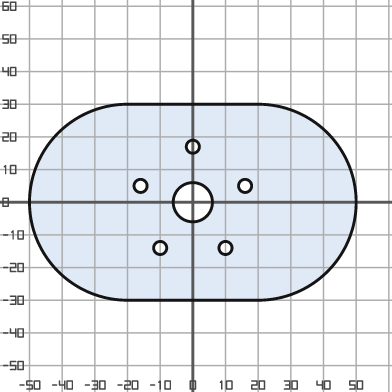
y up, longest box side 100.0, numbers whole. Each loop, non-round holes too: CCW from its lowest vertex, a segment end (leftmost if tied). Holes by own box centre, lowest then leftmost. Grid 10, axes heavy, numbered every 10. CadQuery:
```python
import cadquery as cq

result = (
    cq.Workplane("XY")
    .moveTo(-20.0, -30.0)
    .lineTo(20.0, -30.0)
    .threePointArc((50.0, 0.0), (20.0, 30.0))
    .lineTo(-20.0, 30.0)
    .threePointArc((-50.0, 0.0), (-20.0, -30.0))
    .close()
    .moveTo(-10.0, -14.0)
    .circle(2.0)
    .moveTo(10.0, -14.0)
    .circle(2.0)
    .moveTo(0.0, 0.0)
    .circle(6.0)
    .moveTo(-16.0, 5.0)
    .circle(2.0)
    .moveTo(16.0, 5.0)
    .circle(2.0)
    .moveTo(0.0, 17.0)
    .circle(2.0)
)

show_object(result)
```